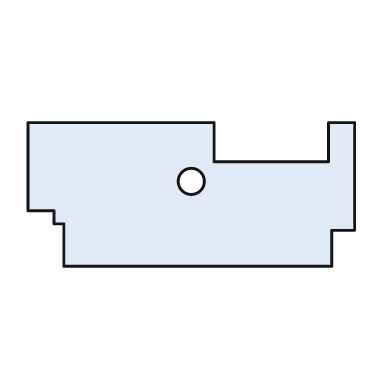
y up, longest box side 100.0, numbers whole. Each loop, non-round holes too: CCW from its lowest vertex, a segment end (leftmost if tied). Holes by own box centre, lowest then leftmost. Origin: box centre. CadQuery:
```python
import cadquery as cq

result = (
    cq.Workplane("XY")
    .moveTo(-39.0, -22.0)
    .lineTo(43.0, -22.0)
    .lineTo(43.0, -11.0)
    .lineTo(50.0, -11.0)
    .lineTo(50.0, 22.0)
    .lineTo(42.0, 22.0)
    .lineTo(42.0, 10.0)
    .lineTo(7.0, 10.0)
    .lineTo(7.0, 22.0)
    .lineTo(-50.0, 22.0)
    .lineTo(-50.0, -5.0)
    .lineTo(-42.0, -5.0)
    .lineTo(-42.0, -9.0)
    .lineTo(-39.0, -9.0)
    .close()
    .moveTo(0.0, 4.0)
    .circle(4.0)
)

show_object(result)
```